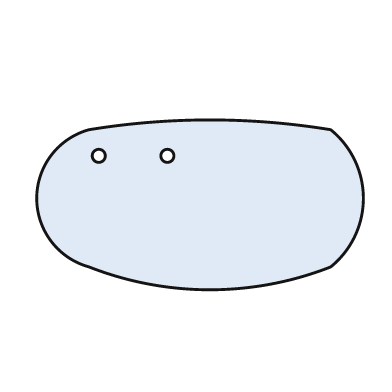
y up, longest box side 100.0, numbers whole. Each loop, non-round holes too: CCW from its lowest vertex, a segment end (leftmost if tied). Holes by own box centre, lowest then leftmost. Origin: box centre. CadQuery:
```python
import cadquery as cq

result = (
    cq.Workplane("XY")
    .moveTo(-34.0, -19.0)
    .threePointArc((3.0, -26.0), (40.0, -19.0))
    .threePointArc((50.0, 2.0), (40.0, 23.0))
    .threePointArc((3.0, 26.0), (-34.0, 23.0))
    .threePointArc((-50.0, 2.0), (-34.0, -19.0))
    .close()
    .moveTo(-31.0, 15.0)
    .circle(2.0)
    .moveTo(-10.0, 15.0)
    .circle(2.0)
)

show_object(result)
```